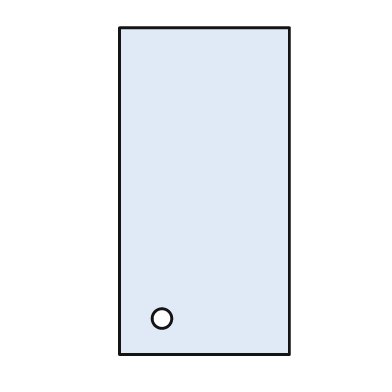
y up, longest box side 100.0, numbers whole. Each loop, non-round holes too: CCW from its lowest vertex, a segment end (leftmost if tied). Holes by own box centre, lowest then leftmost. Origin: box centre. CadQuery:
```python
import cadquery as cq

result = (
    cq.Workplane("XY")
    .moveTo(-26.0, -50.0)
    .lineTo(26.0, -50.0)
    .lineTo(26.0, 50.0)
    .lineTo(-26.0, 50.0)
    .close()
    .moveTo(-13.0, -39.0)
    .circle(3.0)
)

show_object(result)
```